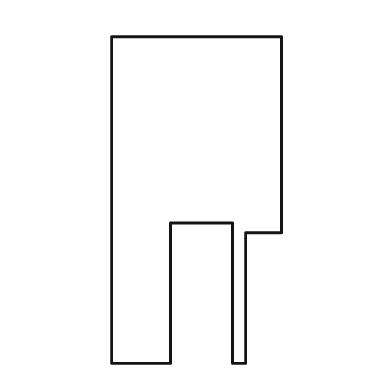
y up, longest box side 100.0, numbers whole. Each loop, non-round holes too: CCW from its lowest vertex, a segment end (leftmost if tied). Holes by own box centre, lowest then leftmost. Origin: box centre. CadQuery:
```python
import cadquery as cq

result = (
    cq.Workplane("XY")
    .moveTo(-26.0, -50.0)
    .lineTo(-8.0, -50.0)
    .lineTo(-8.0, -7.0)
    .lineTo(11.0, -7.0)
    .lineTo(11.0, -50.0)
    .lineTo(15.0, -50.0)
    .lineTo(15.0, -10.0)
    .lineTo(26.0, -10.0)
    .lineTo(26.0, 50.0)
    .lineTo(-26.0, 50.0)
    .close()
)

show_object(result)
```